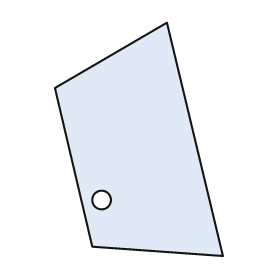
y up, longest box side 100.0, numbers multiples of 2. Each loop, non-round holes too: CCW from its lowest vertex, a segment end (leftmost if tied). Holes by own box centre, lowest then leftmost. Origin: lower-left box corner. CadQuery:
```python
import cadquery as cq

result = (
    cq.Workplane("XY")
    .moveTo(72.0, 0.0)
    .lineTo(48.0, 100.0)
    .lineTo(0.0, 72.0)
    .lineTo(16.0, 4.0)
    .close()
    .moveTo(20.0, 24.0)
    .circle(4.0)
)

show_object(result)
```